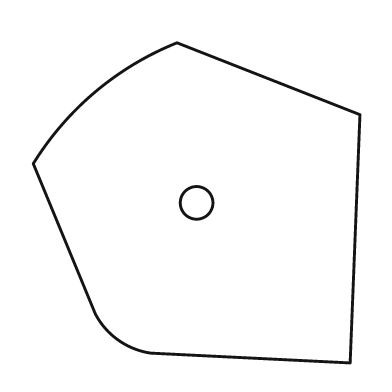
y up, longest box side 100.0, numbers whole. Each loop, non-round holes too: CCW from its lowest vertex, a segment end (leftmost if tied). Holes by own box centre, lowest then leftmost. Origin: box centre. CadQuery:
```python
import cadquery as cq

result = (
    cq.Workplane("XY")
    .moveTo(47.0, -49.0)
    .lineTo(50.0, 27.0)
    .lineTo(-6.0, 49.0)
    .threePointArc((-31.0, 34.0), (-50.0, 12.0))
    .lineTo(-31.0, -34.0)
    .threePointArc((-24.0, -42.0), (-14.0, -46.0))
    .close()
    .moveTo(0.0, 0.0)
    .circle(5.0)
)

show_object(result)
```